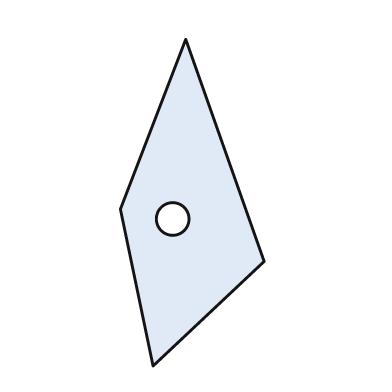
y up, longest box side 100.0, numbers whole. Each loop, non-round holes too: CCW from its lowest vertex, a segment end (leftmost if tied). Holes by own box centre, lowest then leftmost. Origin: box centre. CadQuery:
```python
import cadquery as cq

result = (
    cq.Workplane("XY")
    .moveTo(-12.0, -50.0)
    .lineTo(22.0, -18.0)
    .lineTo(-2.0, 50.0)
    .lineTo(-22.0, -2.0)
    .close()
    .moveTo(-6.0, -5.0)
    .circle(5.0)
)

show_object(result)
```